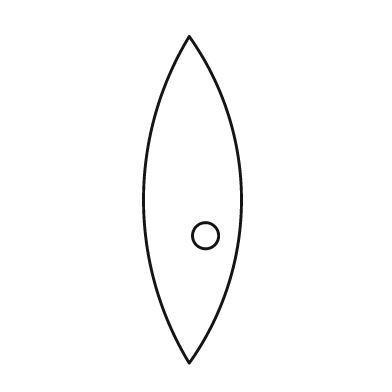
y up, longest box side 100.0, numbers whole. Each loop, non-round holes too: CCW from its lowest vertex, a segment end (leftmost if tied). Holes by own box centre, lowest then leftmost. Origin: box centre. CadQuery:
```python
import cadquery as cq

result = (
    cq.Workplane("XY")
    .moveTo(-1.0, -50.0)
    .threePointArc((15.0, 0.0), (-1.0, 50.0))
    .threePointArc((-15.0, 0.0), (-1.0, -50.0))
    .close()
    .moveTo(4.0, -11.0)
    .circle(4.0)
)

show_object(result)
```